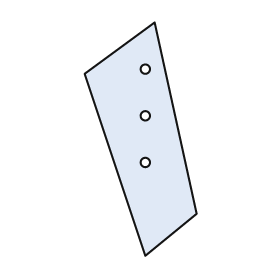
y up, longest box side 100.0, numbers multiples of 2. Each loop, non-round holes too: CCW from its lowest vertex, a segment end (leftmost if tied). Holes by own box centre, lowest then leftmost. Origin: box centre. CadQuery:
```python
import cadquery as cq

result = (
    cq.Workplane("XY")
    .moveTo(2.0, -50.0)
    .lineTo(24.0, -32.0)
    .lineTo(6.0, 50.0)
    .lineTo(-24.0, 28.0)
    .close()
    .moveTo(2.0, -10.0)
    .circle(2.0)
    .moveTo(2.0, 10.0)
    .circle(2.0)
    .moveTo(2.0, 30.0)
    .circle(2.0)
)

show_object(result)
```